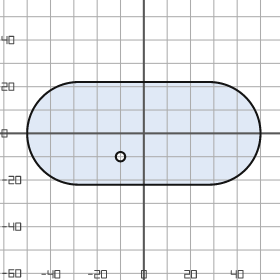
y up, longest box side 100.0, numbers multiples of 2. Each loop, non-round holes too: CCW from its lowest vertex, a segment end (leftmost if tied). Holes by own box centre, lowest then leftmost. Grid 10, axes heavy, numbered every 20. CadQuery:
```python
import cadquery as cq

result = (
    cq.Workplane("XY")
    .moveTo(-28.0, -22.0)
    .lineTo(28.0, -22.0)
    .threePointArc((50.0, 0.0), (28.0, 22.0))
    .lineTo(-28.0, 22.0)
    .threePointArc((-50.0, 0.0), (-28.0, -22.0))
    .close()
    .moveTo(-10.0, -10.0)
    .circle(2.0)
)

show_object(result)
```